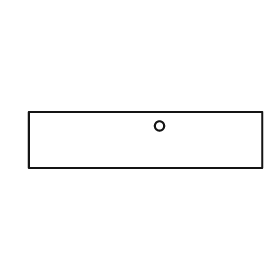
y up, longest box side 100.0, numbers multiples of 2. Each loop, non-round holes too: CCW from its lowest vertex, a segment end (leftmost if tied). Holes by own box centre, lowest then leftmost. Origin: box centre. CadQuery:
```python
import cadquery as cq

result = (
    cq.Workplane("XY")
    .moveTo(-50.0, -12.0)
    .lineTo(50.0, -12.0)
    .lineTo(50.0, 12.0)
    .lineTo(-50.0, 12.0)
    .close()
    .moveTo(6.0, 6.0)
    .circle(2.0)
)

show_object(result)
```